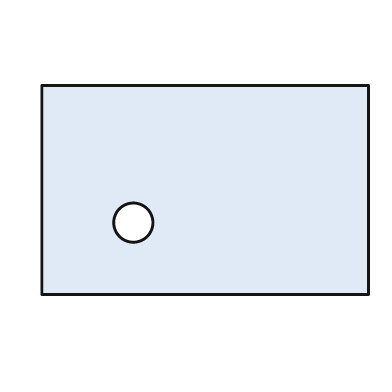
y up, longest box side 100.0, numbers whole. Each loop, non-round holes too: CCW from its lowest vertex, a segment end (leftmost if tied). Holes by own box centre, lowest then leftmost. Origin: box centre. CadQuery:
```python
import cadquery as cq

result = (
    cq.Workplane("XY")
    .moveTo(-50.0, -32.0)
    .lineTo(50.0, -32.0)
    .lineTo(50.0, 32.0)
    .lineTo(-50.0, 32.0)
    .close()
    .moveTo(-22.0, -10.0)
    .circle(6.0)
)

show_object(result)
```